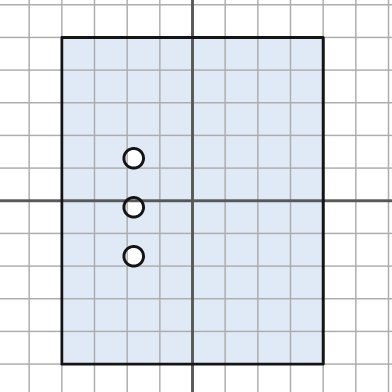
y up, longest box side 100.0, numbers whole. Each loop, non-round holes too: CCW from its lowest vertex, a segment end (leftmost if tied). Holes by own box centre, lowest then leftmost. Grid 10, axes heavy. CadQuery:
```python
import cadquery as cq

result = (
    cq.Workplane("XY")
    .moveTo(-40.0, -50.0)
    .lineTo(40.0, -50.0)
    .lineTo(40.0, 50.0)
    .lineTo(-40.0, 50.0)
    .close()
    .moveTo(-18.0, -17.0)
    .circle(3.0)
    .moveTo(-18.0, -2.0)
    .circle(3.0)
    .moveTo(-18.0, 13.0)
    .circle(3.0)
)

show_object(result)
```